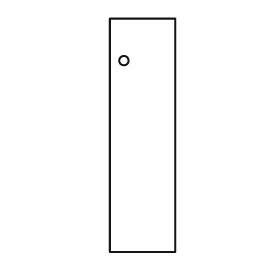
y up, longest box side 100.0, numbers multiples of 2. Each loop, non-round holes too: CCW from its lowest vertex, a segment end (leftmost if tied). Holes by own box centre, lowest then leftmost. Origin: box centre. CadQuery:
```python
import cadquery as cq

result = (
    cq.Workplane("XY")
    .moveTo(-14.0, -50.0)
    .lineTo(14.0, -50.0)
    .lineTo(14.0, 50.0)
    .lineTo(-14.0, 50.0)
    .close()
    .moveTo(-8.0, 32.0)
    .circle(2.0)
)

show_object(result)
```